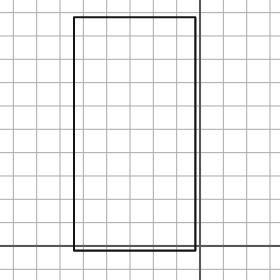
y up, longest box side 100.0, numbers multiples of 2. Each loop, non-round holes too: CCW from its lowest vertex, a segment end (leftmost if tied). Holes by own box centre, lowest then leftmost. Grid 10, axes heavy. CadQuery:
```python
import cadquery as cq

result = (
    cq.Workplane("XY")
    .moveTo(-54.0, -2.0)
    .lineTo(-2.0, -2.0)
    .lineTo(-2.0, 98.0)
    .lineTo(-54.0, 98.0)
    .close()
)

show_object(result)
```